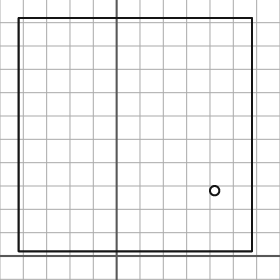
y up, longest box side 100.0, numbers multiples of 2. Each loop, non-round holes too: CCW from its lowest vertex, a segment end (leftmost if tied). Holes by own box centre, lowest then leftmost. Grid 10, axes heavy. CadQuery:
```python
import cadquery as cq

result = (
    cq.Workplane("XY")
    .moveTo(-42.0, 2.0)
    .lineTo(58.0, 2.0)
    .lineTo(58.0, 102.0)
    .lineTo(-42.0, 102.0)
    .close()
    .moveTo(42.0, 28.0)
    .circle(2.0)
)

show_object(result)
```